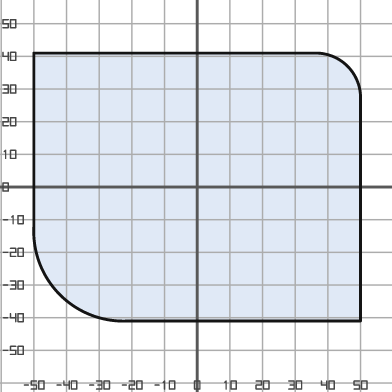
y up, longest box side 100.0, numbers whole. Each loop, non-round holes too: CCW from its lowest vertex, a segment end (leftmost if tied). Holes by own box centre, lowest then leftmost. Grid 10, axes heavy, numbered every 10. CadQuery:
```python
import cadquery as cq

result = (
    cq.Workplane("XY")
    .moveTo(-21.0, -41.0)
    .lineTo(50.0, -41.0)
    .lineTo(50.0, 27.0)
    .threePointArc((46.0, 37.0), (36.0, 41.0))
    .lineTo(-50.0, 41.0)
    .lineTo(-50.0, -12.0)
    .threePointArc((-42.0, -33.0), (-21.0, -41.0))
    .close()
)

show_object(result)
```